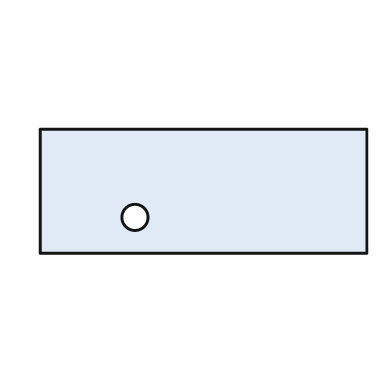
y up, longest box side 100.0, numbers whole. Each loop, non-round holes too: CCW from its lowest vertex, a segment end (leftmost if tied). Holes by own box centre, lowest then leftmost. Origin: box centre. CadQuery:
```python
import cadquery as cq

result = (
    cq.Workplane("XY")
    .moveTo(-50.0, -19.0)
    .lineTo(50.0, -19.0)
    .lineTo(50.0, 19.0)
    .lineTo(-50.0, 19.0)
    .close()
    .moveTo(-21.0, -8.0)
    .circle(4.0)
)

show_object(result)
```